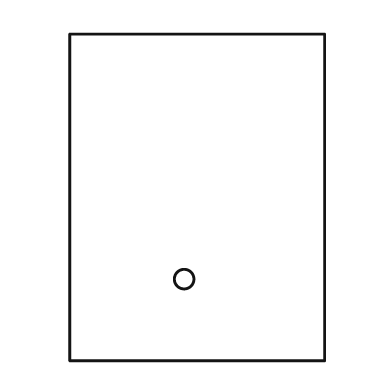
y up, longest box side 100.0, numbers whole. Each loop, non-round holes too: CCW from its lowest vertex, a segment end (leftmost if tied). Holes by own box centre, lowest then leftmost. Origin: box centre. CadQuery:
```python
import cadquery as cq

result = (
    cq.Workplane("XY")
    .moveTo(-39.0, -50.0)
    .lineTo(39.0, -50.0)
    .lineTo(39.0, 50.0)
    .lineTo(-39.0, 50.0)
    .close()
    .moveTo(-4.0, -25.0)
    .circle(3.0)
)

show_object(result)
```